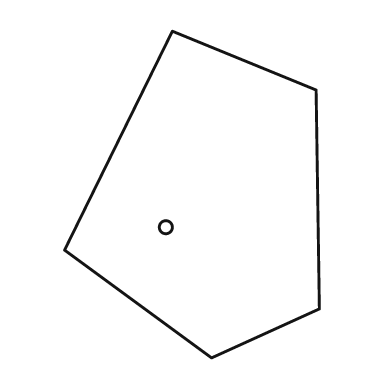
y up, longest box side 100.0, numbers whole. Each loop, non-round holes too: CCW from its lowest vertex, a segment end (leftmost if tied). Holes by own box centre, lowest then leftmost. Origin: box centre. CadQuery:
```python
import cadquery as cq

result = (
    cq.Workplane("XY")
    .moveTo(6.0, -50.0)
    .lineTo(39.0, -35.0)
    .lineTo(38.0, 32.0)
    .lineTo(-6.0, 50.0)
    .lineTo(-39.0, -17.0)
    .close()
    .moveTo(-8.0, -10.0)
    .circle(2.0)
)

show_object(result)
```